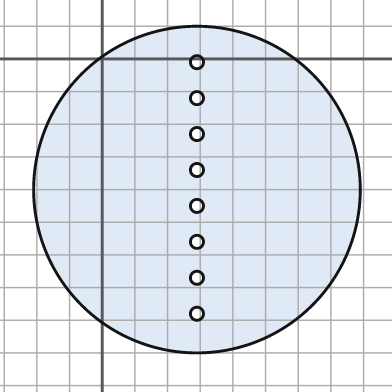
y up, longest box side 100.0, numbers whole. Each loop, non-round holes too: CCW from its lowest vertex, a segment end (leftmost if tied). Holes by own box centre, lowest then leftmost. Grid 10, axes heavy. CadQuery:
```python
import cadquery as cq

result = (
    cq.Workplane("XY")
    .moveTo(29.0, -40.0)
    .circle(50.0)
    .moveTo(29.0, -78.0)
    .circle(2.0)
    .moveTo(29.0, -67.0)
    .circle(2.0)
    .moveTo(29.0, -56.0)
    .circle(2.0)
    .moveTo(29.0, -45.0)
    .circle(2.0)
    .moveTo(29.0, -34.0)
    .circle(2.0)
    .moveTo(29.0, -23.0)
    .circle(2.0)
    .moveTo(29.0, -12.0)
    .circle(2.0)
    .moveTo(29.0, -1.0)
    .circle(2.0)
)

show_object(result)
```